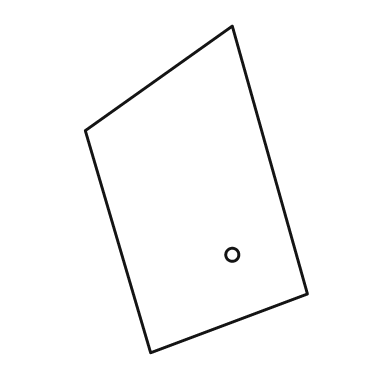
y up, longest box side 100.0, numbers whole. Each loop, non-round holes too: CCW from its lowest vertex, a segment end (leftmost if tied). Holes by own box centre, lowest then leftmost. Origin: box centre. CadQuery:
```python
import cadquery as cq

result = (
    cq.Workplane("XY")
    .moveTo(-14.0, -50.0)
    .lineTo(34.0, -32.0)
    .lineTo(11.0, 50.0)
    .lineTo(-34.0, 18.0)
    .close()
    .moveTo(11.0, -20.0)
    .circle(2.0)
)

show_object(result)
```